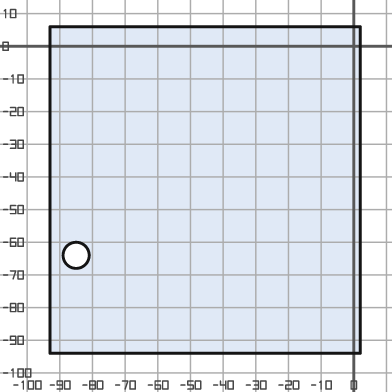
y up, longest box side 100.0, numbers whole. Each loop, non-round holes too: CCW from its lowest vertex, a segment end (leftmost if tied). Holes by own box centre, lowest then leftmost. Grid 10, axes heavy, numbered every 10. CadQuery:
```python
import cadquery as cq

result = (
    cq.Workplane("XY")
    .moveTo(-93.0, -94.0)
    .lineTo(2.0, -94.0)
    .lineTo(2.0, 6.0)
    .lineTo(-93.0, 6.0)
    .close()
    .moveTo(-85.0, -64.0)
    .circle(4.0)
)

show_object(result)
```